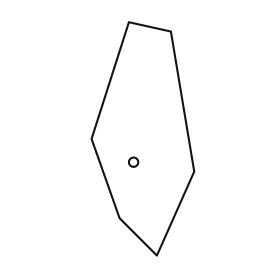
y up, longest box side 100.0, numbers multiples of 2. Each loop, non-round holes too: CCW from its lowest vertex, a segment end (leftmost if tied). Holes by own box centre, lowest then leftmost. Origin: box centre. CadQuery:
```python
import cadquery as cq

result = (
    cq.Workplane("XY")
    .moveTo(6.0, -50.0)
    .lineTo(22.0, -14.0)
    .lineTo(12.0, 46.0)
    .lineTo(-6.0, 50.0)
    .lineTo(-22.0, 0.0)
    .lineTo(-10.0, -34.0)
    .close()
    .moveTo(-4.0, -10.0)
    .circle(2.0)
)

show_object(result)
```